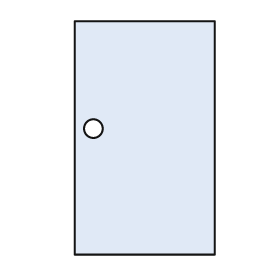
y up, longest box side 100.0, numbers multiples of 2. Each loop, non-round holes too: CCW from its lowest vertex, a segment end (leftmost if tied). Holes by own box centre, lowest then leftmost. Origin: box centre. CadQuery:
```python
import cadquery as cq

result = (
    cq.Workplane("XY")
    .moveTo(-30.0, -50.0)
    .lineTo(30.0, -50.0)
    .lineTo(30.0, 50.0)
    .lineTo(-30.0, 50.0)
    .close()
    .moveTo(-22.0, 4.0)
    .circle(4.0)
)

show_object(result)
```